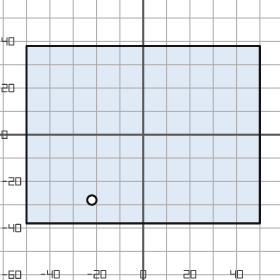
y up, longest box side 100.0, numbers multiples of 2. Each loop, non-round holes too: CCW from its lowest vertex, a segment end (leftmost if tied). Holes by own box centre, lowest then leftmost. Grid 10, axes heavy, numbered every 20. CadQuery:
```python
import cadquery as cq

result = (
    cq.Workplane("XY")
    .moveTo(-50.0, -38.0)
    .lineTo(50.0, -38.0)
    .lineTo(50.0, 38.0)
    .lineTo(-50.0, 38.0)
    .close()
    .moveTo(-22.0, -28.0)
    .circle(2.0)
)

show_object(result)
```